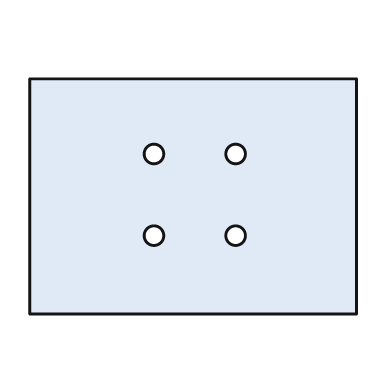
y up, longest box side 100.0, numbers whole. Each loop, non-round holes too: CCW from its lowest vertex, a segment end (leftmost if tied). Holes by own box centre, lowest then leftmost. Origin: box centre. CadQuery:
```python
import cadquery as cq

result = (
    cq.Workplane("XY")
    .moveTo(-50.0, -36.0)
    .lineTo(50.0, -36.0)
    .lineTo(50.0, 36.0)
    .lineTo(-50.0, 36.0)
    .close()
    .moveTo(-12.0, -12.0)
    .circle(3.0)
    .moveTo(13.0, -12.0)
    .circle(3.0)
    .moveTo(-12.0, 13.0)
    .circle(3.0)
    .moveTo(13.0, 13.0)
    .circle(3.0)
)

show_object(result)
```